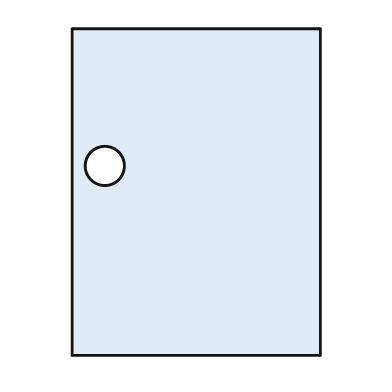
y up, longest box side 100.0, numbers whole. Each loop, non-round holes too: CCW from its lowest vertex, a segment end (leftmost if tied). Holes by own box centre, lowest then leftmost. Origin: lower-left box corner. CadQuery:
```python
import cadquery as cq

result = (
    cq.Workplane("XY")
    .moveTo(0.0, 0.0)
    .lineTo(76.0, 0.0)
    .lineTo(76.0, 100.0)
    .lineTo(0.0, 100.0)
    .close()
    .moveTo(10.0, 58.0)
    .circle(6.0)
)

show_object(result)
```